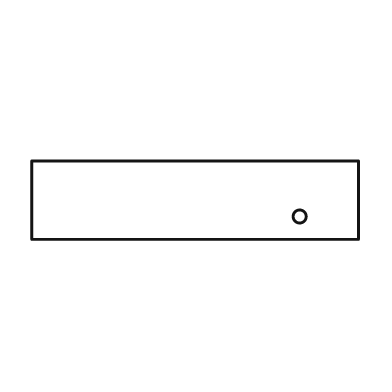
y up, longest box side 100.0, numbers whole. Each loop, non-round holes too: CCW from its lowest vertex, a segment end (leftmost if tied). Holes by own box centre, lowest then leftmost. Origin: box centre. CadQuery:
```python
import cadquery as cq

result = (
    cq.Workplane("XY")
    .moveTo(-50.0, -12.0)
    .lineTo(50.0, -12.0)
    .lineTo(50.0, 12.0)
    .lineTo(-50.0, 12.0)
    .close()
    .moveTo(32.0, -5.0)
    .circle(2.0)
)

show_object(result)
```